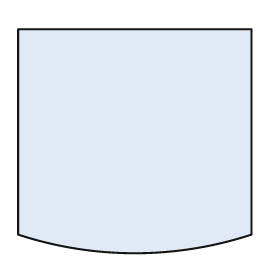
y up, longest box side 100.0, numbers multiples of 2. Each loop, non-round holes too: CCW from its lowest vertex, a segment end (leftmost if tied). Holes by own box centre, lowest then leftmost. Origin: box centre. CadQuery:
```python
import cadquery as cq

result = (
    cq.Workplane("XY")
    .moveTo(-50.0, -40.0)
    .threePointArc((0.0, -48.0), (50.0, -40.0))
    .lineTo(50.0, 48.0)
    .lineTo(-50.0, 48.0)
    .close()
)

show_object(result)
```